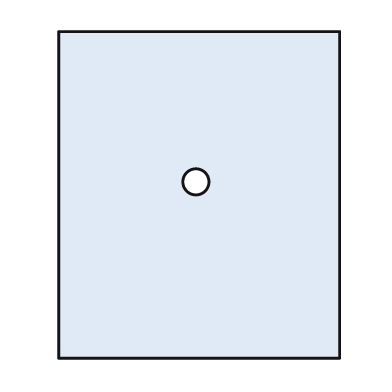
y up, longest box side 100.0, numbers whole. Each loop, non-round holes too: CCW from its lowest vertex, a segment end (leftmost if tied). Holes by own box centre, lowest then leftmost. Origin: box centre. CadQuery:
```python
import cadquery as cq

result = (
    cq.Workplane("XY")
    .moveTo(-43.0, -50.0)
    .lineTo(43.0, -50.0)
    .lineTo(43.0, 50.0)
    .lineTo(-43.0, 50.0)
    .close()
    .moveTo(-1.0, 4.0)
    .circle(4.0)
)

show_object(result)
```